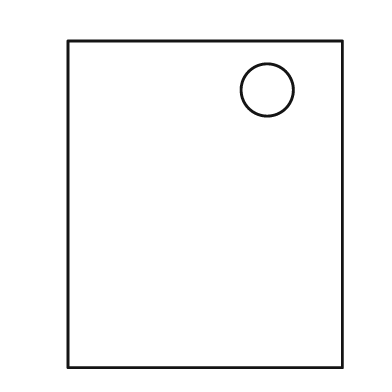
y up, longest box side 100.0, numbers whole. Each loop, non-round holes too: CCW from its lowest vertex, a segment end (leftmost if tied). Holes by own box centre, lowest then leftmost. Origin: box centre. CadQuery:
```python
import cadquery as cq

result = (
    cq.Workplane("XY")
    .moveTo(-42.0, -50.0)
    .lineTo(42.0, -50.0)
    .lineTo(42.0, 50.0)
    .lineTo(-42.0, 50.0)
    .close()
    .moveTo(19.0, 35.0)
    .circle(8.0)
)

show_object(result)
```